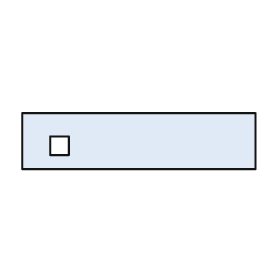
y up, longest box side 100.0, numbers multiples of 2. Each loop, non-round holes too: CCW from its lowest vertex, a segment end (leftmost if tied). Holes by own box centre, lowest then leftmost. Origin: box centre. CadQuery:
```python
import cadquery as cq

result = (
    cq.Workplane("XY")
    .moveTo(-50.0, -12.0)
    .lineTo(50.0, -12.0)
    .lineTo(50.0, 12.0)
    .lineTo(-50.0, 12.0)
    .close()
    .moveTo(-38.0, -6.0)
    .lineTo(-30.0, -6.0)
    .lineTo(-30.0, 2.0)
    .lineTo(-38.0, 2.0)
    .close()
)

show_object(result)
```